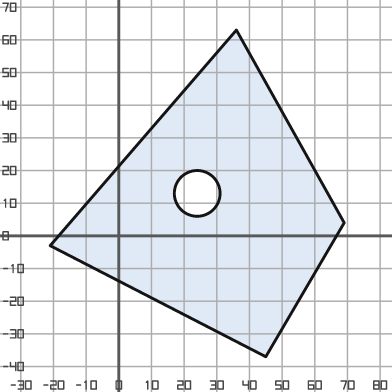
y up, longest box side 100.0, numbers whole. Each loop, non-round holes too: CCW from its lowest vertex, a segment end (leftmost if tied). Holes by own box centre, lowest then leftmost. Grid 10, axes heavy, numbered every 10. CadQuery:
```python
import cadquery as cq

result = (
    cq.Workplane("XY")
    .moveTo(45.0, -37.0)
    .lineTo(69.0, 4.0)
    .lineTo(36.0, 63.0)
    .lineTo(-21.0, -3.0)
    .close()
    .moveTo(24.0, 13.0)
    .circle(7.0)
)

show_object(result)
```